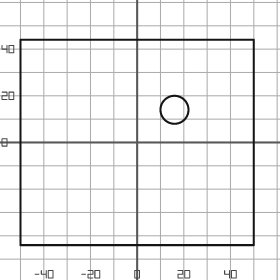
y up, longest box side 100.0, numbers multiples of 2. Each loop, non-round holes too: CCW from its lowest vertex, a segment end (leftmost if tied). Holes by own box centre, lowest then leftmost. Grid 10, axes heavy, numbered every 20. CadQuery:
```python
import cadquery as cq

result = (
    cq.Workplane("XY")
    .moveTo(-50.0, -44.0)
    .lineTo(50.0, -44.0)
    .lineTo(50.0, 44.0)
    .lineTo(-50.0, 44.0)
    .close()
    .moveTo(16.0, 14.0)
    .circle(6.0)
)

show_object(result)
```